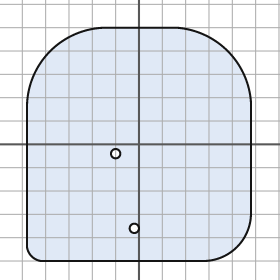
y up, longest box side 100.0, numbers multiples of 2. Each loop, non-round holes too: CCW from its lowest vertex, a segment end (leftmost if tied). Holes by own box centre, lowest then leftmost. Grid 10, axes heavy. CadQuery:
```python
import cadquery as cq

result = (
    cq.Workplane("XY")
    .moveTo(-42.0, -50.0)
    .lineTo(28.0, -50.0)
    .threePointArc((42.0, -44.0), (48.0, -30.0))
    .lineTo(48.0, 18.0)
    .threePointArc((38.0, 40.0), (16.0, 50.0))
    .lineTo(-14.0, 50.0)
    .threePointArc((-38.0, 40.0), (-48.0, 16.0))
    .lineTo(-48.0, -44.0)
    .threePointArc((-46.0, -48.0), (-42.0, -50.0))
    .close()
    .moveTo(-2.0, -36.0)
    .circle(2.0)
    .moveTo(-10.0, -4.0)
    .circle(2.0)
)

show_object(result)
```